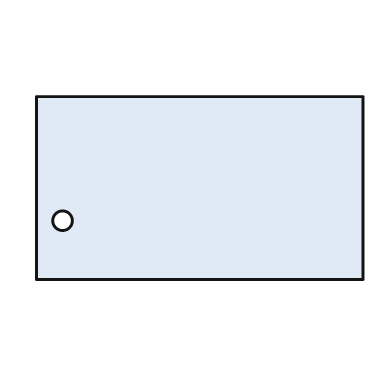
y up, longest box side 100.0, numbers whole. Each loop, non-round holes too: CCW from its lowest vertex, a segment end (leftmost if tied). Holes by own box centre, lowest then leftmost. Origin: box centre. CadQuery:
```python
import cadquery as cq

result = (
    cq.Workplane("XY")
    .moveTo(-50.0, -28.0)
    .lineTo(50.0, -28.0)
    .lineTo(50.0, 28.0)
    .lineTo(-50.0, 28.0)
    .close()
    .moveTo(-42.0, -10.0)
    .circle(3.0)
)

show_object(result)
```